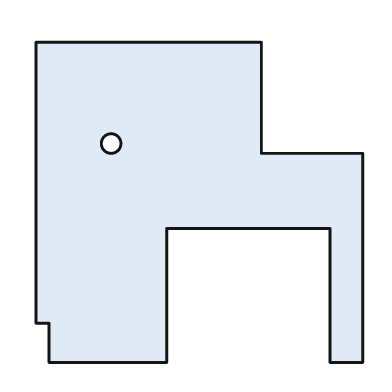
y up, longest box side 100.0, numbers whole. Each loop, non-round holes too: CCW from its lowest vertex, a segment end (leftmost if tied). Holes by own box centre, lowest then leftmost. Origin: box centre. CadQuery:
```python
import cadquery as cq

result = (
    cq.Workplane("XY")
    .moveTo(-46.0, -49.0)
    .lineTo(-10.0, -49.0)
    .lineTo(-10.0, -8.0)
    .lineTo(40.0, -8.0)
    .lineTo(40.0, -49.0)
    .lineTo(50.0, -49.0)
    .lineTo(50.0, 15.0)
    .lineTo(19.0, 15.0)
    .lineTo(19.0, 49.0)
    .lineTo(-50.0, 49.0)
    .lineTo(-50.0, -37.0)
    .lineTo(-46.0, -37.0)
    .close()
    .moveTo(-27.0, 18.0)
    .circle(3.0)
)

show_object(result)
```